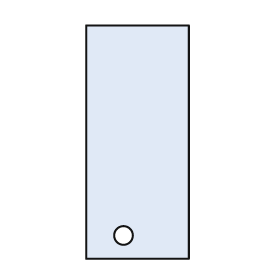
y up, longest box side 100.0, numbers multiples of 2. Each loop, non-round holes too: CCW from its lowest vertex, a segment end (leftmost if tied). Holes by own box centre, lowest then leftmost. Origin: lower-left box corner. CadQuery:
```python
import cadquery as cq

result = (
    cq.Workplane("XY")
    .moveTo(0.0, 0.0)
    .lineTo(44.0, 0.0)
    .lineTo(44.0, 100.0)
    .lineTo(0.0, 100.0)
    .close()
    .moveTo(16.0, 10.0)
    .circle(4.0)
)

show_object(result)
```